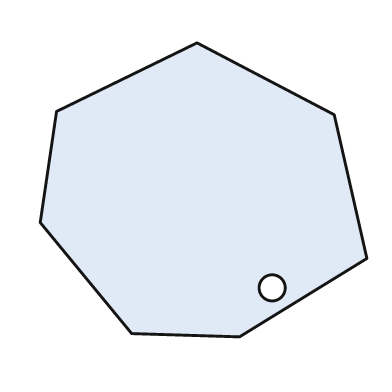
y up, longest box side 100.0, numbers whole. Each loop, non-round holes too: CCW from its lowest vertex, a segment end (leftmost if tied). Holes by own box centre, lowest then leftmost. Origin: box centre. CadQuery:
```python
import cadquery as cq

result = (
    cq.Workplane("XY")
    .moveTo(11.0, -45.0)
    .lineTo(50.0, -21.0)
    .lineTo(40.0, 23.0)
    .lineTo(-2.0, 45.0)
    .lineTo(-45.0, 24.0)
    .lineTo(-50.0, -10.0)
    .lineTo(-22.0, -44.0)
    .close()
    .moveTo(21.0, -30.0)
    .circle(4.0)
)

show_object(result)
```